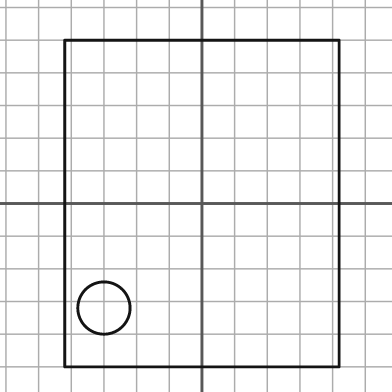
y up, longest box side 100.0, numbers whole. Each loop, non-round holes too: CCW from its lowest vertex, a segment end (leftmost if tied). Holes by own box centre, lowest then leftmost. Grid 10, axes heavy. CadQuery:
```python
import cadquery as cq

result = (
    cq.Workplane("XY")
    .moveTo(-42.0, -50.0)
    .lineTo(42.0, -50.0)
    .lineTo(42.0, 50.0)
    .lineTo(-42.0, 50.0)
    .close()
    .moveTo(-30.0, -32.0)
    .circle(8.0)
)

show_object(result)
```